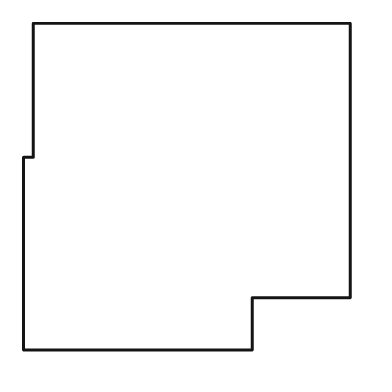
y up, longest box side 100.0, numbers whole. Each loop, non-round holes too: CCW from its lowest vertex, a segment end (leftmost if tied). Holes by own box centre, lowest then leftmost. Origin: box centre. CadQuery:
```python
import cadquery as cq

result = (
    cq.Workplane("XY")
    .moveTo(-50.0, -50.0)
    .lineTo(20.0, -50.0)
    .lineTo(20.0, -34.0)
    .lineTo(50.0, -34.0)
    .lineTo(50.0, 50.0)
    .lineTo(-47.0, 50.0)
    .lineTo(-47.0, 9.0)
    .lineTo(-50.0, 9.0)
    .close()
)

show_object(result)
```